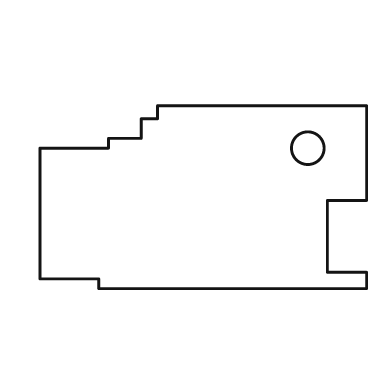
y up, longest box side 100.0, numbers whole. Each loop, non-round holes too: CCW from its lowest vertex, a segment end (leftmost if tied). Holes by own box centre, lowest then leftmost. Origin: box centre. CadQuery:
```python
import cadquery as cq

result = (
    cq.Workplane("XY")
    .moveTo(-32.0, -28.0)
    .lineTo(50.0, -28.0)
    .lineTo(50.0, -23.0)
    .lineTo(38.0, -23.0)
    .lineTo(38.0, -1.0)
    .lineTo(50.0, -1.0)
    .lineTo(50.0, 28.0)
    .lineTo(-14.0, 28.0)
    .lineTo(-14.0, 24.0)
    .lineTo(-19.0, 24.0)
    .lineTo(-19.0, 18.0)
    .lineTo(-29.0, 18.0)
    .lineTo(-29.0, 15.0)
    .lineTo(-50.0, 15.0)
    .lineTo(-50.0, -25.0)
    .lineTo(-32.0, -25.0)
    .close()
    .moveTo(32.0, 15.0)
    .circle(5.0)
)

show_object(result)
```